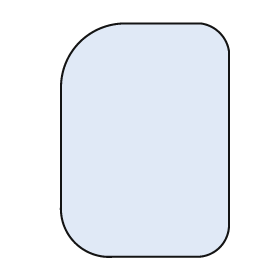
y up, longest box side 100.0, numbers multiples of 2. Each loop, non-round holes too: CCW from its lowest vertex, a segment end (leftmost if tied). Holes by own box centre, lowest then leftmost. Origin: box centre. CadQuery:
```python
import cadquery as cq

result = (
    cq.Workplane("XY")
    .moveTo(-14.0, -50.0)
    .lineTo(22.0, -50.0)
    .threePointArc((32.0, -46.0), (36.0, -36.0))
    .lineTo(36.0, 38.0)
    .threePointArc((32.0, 46.0), (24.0, 50.0))
    .lineTo(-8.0, 50.0)
    .threePointArc((-28.0, 42.0), (-36.0, 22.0))
    .lineTo(-36.0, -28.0)
    .threePointArc((-30.0, -44.0), (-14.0, -50.0))
    .close()
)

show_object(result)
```